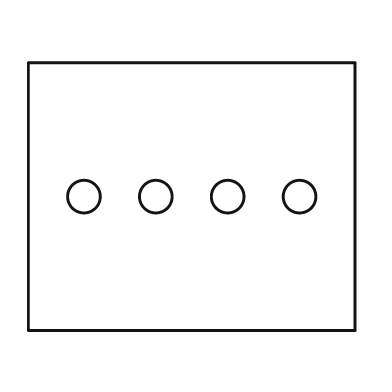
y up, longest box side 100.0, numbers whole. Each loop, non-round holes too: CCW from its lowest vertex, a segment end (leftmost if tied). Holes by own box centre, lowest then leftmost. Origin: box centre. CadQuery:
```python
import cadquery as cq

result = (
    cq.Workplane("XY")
    .moveTo(-50.0, -41.0)
    .lineTo(50.0, -41.0)
    .lineTo(50.0, 41.0)
    .lineTo(-50.0, 41.0)
    .close()
    .moveTo(-33.0, 0.0)
    .circle(5.0)
    .moveTo(-11.0, 0.0)
    .circle(5.0)
    .moveTo(11.0, 0.0)
    .circle(5.0)
    .moveTo(33.0, 0.0)
    .circle(5.0)
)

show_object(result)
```